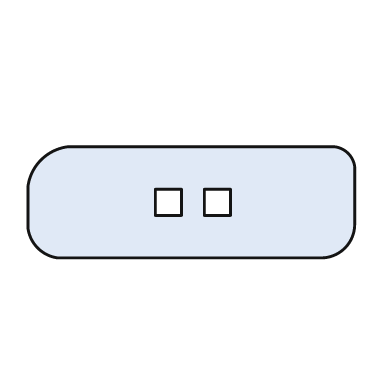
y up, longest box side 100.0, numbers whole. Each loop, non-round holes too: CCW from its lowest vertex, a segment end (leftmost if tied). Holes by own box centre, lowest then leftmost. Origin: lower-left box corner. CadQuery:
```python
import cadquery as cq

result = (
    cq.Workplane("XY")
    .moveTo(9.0, 0.0)
    .lineTo(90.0, 0.0)
    .threePointArc((97.0, 3.0), (100.0, 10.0))
    .lineTo(100.0, 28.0)
    .threePointArc((98.0, 32.0), (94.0, 34.0))
    .lineTo(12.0, 34.0)
    .threePointArc((4.0, 30.0), (0.0, 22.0))
    .lineTo(0.0, 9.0)
    .threePointArc((3.0, 3.0), (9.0, 0.0))
    .close()
    .moveTo(39.0, 13.0)
    .lineTo(47.0, 13.0)
    .lineTo(47.0, 21.0)
    .lineTo(39.0, 21.0)
    .close()
    .moveTo(54.0, 13.0)
    .lineTo(62.0, 13.0)
    .lineTo(62.0, 21.0)
    .lineTo(54.0, 21.0)
    .close()
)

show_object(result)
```